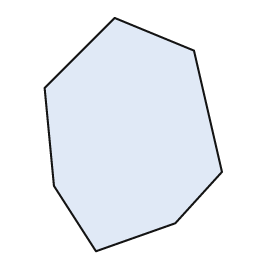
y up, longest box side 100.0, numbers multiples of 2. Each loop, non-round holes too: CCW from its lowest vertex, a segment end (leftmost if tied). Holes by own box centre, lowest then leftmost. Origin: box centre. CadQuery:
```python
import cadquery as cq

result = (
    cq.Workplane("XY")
    .moveTo(-16.0, -50.0)
    .lineTo(18.0, -38.0)
    .lineTo(38.0, -16.0)
    .lineTo(26.0, 36.0)
    .lineTo(-8.0, 50.0)
    .lineTo(-38.0, 20.0)
    .lineTo(-34.0, -22.0)
    .close()
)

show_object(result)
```